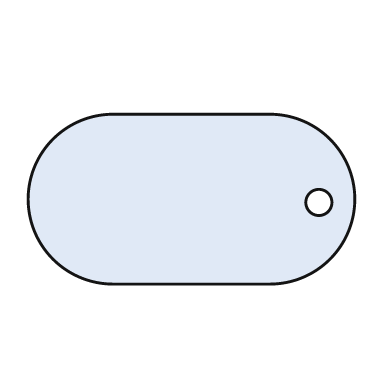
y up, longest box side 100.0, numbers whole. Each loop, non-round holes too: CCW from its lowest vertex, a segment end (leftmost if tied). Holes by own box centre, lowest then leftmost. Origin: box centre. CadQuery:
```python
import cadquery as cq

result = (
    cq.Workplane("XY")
    .moveTo(-24.0, -26.0)
    .lineTo(24.0, -26.0)
    .threePointArc((50.0, 0.0), (24.0, 26.0))
    .lineTo(-24.0, 26.0)
    .threePointArc((-50.0, 0.0), (-24.0, -26.0))
    .close()
    .moveTo(39.0, -1.0)
    .circle(4.0)
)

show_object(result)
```